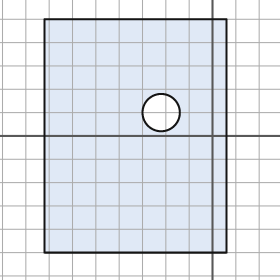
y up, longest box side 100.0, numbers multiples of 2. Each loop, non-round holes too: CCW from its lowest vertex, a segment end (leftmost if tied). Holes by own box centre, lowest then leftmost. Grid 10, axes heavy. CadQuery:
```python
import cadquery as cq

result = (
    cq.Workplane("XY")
    .moveTo(-72.0, -50.0)
    .lineTo(6.0, -50.0)
    .lineTo(6.0, 50.0)
    .lineTo(-72.0, 50.0)
    .close()
    .moveTo(-22.0, 10.0)
    .circle(8.0)
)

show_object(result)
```